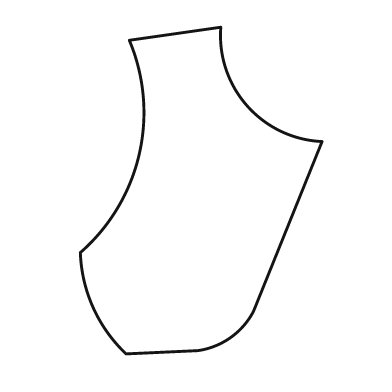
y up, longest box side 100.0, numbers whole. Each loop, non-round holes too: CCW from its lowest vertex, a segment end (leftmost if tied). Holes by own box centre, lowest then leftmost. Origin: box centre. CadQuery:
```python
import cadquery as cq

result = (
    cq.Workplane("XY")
    .moveTo(-23.0, -50.0)
    .lineTo(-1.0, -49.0)
    .threePointArc((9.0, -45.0), (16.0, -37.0))
    .lineTo(37.0, 15.0)
    .threePointArc((14.0, 26.0), (6.0, 50.0))
    .lineTo(-22.0, 46.0)
    .threePointArc((-19.0, 11.0), (-37.0, -19.0))
    .threePointArc((-33.0, -36.0), (-23.0, -50.0))
    .close()
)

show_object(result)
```